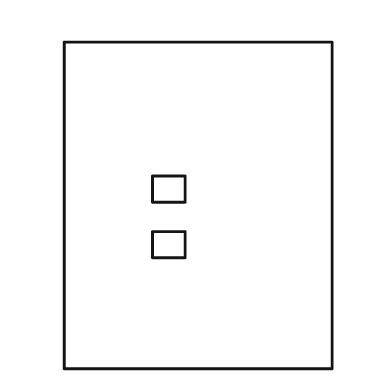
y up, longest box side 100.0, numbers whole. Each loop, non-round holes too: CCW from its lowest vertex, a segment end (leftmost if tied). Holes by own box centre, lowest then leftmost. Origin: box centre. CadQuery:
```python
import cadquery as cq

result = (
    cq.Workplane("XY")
    .moveTo(-41.0, -50.0)
    .lineTo(41.0, -50.0)
    .lineTo(41.0, 50.0)
    .lineTo(-41.0, 50.0)
    .close()
    .moveTo(-14.0, -16.0)
    .lineTo(-4.0, -16.0)
    .lineTo(-4.0, -8.0)
    .lineTo(-14.0, -8.0)
    .close()
    .moveTo(-14.0, 1.0)
    .lineTo(-4.0, 1.0)
    .lineTo(-4.0, 9.0)
    .lineTo(-14.0, 9.0)
    .close()
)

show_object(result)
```